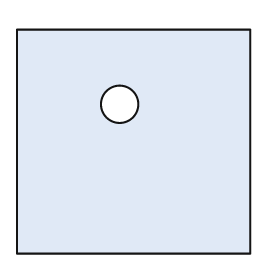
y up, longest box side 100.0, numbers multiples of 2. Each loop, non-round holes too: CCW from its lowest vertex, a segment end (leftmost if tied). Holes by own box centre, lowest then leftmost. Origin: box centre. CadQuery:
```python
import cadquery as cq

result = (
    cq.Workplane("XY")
    .moveTo(-50.0, -48.0)
    .lineTo(50.0, -48.0)
    .lineTo(50.0, 48.0)
    .lineTo(-50.0, 48.0)
    .close()
    .moveTo(-6.0, 16.0)
    .circle(8.0)
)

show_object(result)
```